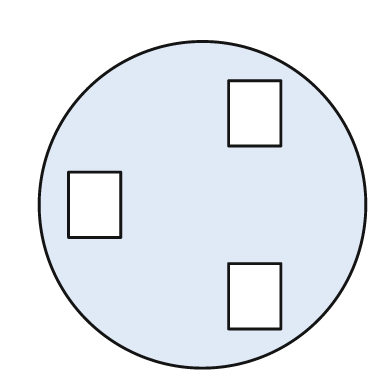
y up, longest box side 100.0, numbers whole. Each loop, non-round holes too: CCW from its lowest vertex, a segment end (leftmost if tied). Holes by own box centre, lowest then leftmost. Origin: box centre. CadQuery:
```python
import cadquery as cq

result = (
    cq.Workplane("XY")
    .moveTo(0.0, 0.0)
    .circle(50.0)
    .moveTo(8.0, -38.0)
    .lineTo(24.0, -38.0)
    .lineTo(24.0, -18.0)
    .lineTo(8.0, -18.0)
    .close()
    .moveTo(-41.0, -10.0)
    .lineTo(-25.0, -10.0)
    .lineTo(-25.0, 10.0)
    .lineTo(-41.0, 10.0)
    .close()
    .moveTo(8.0, 18.0)
    .lineTo(24.0, 18.0)
    .lineTo(24.0, 38.0)
    .lineTo(8.0, 38.0)
    .close()
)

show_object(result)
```